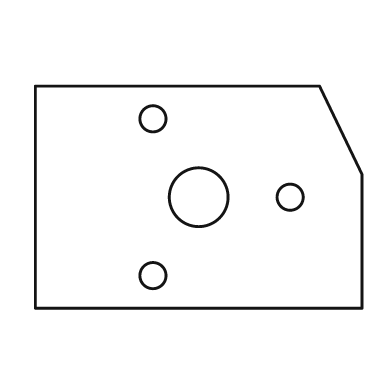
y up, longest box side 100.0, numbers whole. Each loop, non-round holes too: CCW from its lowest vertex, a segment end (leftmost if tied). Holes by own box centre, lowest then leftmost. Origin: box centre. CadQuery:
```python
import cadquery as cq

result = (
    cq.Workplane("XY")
    .moveTo(-50.0, -34.0)
    .lineTo(50.0, -34.0)
    .lineTo(50.0, 7.0)
    .lineTo(37.0, 34.0)
    .lineTo(-50.0, 34.0)
    .close()
    .moveTo(-14.0, -24.0)
    .circle(4.0)
    .moveTo(0.0, 0.0)
    .circle(9.0)
    .moveTo(28.0, 0.0)
    .circle(4.0)
    .moveTo(-14.0, 24.0)
    .circle(4.0)
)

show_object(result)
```